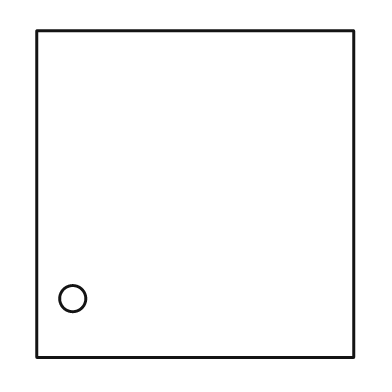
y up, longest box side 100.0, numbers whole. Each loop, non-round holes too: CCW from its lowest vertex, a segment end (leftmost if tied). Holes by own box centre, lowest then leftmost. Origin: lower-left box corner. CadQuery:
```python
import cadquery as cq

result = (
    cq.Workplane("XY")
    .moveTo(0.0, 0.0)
    .lineTo(97.0, 0.0)
    .lineTo(97.0, 100.0)
    .lineTo(0.0, 100.0)
    .close()
    .moveTo(11.0, 18.0)
    .circle(4.0)
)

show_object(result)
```